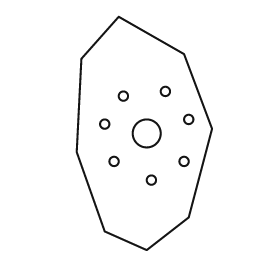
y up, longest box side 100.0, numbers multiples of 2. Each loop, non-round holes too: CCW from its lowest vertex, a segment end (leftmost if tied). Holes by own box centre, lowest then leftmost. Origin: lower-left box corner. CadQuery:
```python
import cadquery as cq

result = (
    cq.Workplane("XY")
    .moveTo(30.0, 0.0)
    .lineTo(48.0, 14.0)
    .lineTo(58.0, 52.0)
    .lineTo(46.0, 84.0)
    .lineTo(18.0, 100.0)
    .lineTo(2.0, 82.0)
    .lineTo(0.0, 42.0)
    .lineTo(12.0, 8.0)
    .close()
    .moveTo(32.0, 30.0)
    .circle(2.0)
    .moveTo(16.0, 38.0)
    .circle(2.0)
    .moveTo(46.0, 38.0)
    .circle(2.0)
    .moveTo(30.0, 50.0)
    .circle(6.0)
    .moveTo(12.0, 54.0)
    .circle(2.0)
    .moveTo(48.0, 56.0)
    .circle(2.0)
    .moveTo(20.0, 66.0)
    .circle(2.0)
    .moveTo(38.0, 68.0)
    .circle(2.0)
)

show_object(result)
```